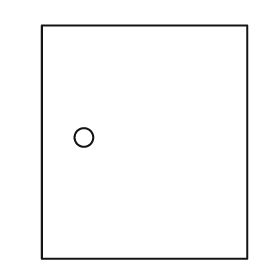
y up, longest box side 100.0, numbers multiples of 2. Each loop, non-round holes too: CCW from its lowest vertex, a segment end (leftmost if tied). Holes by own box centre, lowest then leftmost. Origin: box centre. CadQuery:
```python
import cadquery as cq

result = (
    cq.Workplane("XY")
    .moveTo(-44.0, -50.0)
    .lineTo(44.0, -50.0)
    .lineTo(44.0, 50.0)
    .lineTo(-44.0, 50.0)
    .close()
    .moveTo(-26.0, 2.0)
    .circle(4.0)
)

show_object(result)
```